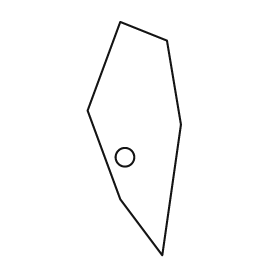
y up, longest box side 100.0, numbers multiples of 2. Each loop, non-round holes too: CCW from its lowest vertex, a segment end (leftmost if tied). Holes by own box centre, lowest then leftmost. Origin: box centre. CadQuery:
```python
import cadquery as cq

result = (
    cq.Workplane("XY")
    .moveTo(12.0, -50.0)
    .lineTo(20.0, 6.0)
    .lineTo(14.0, 42.0)
    .lineTo(-6.0, 50.0)
    .lineTo(-20.0, 12.0)
    .lineTo(-6.0, -26.0)
    .close()
    .moveTo(-4.0, -8.0)
    .circle(4.0)
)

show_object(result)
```